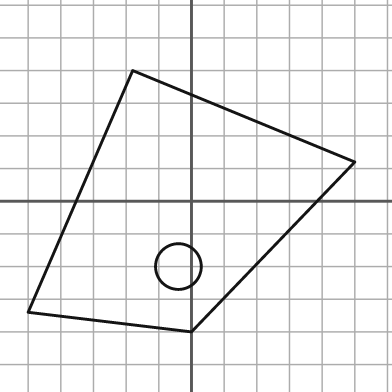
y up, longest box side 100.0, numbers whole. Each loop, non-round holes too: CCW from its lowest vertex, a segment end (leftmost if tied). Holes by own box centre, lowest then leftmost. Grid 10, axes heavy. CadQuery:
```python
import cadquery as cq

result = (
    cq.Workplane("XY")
    .moveTo(0.0, -40.0)
    .lineTo(50.0, 12.0)
    .lineTo(-18.0, 40.0)
    .lineTo(-50.0, -34.0)
    .close()
    .moveTo(-4.0, -20.0)
    .circle(7.0)
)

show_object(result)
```